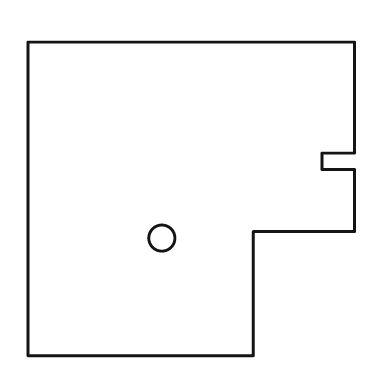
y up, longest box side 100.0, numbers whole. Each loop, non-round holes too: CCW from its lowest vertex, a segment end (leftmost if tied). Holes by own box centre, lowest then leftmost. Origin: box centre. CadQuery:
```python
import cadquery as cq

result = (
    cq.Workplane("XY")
    .moveTo(-50.0, -48.0)
    .lineTo(19.0, -48.0)
    .lineTo(19.0, -10.0)
    .lineTo(50.0, -10.0)
    .lineTo(50.0, 9.0)
    .lineTo(40.0, 9.0)
    .lineTo(40.0, 14.0)
    .lineTo(50.0, 14.0)
    .lineTo(50.0, 48.0)
    .lineTo(-50.0, 48.0)
    .close()
    .moveTo(-9.0, -12.0)
    .circle(4.0)
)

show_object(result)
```